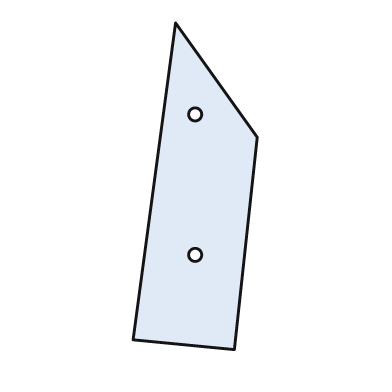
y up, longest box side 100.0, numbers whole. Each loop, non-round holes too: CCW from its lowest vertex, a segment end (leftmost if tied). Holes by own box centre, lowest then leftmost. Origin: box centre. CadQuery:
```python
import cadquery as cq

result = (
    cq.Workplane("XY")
    .moveTo(12.0, -50.0)
    .lineTo(19.0, 15.0)
    .lineTo(-6.0, 50.0)
    .lineTo(-19.0, -47.0)
    .close()
    .moveTo(0.0, -21.0)
    .circle(2.0)
    .moveTo(0.0, 22.0)
    .circle(2.0)
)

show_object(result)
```